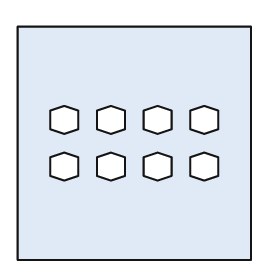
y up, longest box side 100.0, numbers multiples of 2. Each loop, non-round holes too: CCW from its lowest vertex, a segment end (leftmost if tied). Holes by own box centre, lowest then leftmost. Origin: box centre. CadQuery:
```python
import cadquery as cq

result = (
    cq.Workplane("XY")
    .moveTo(-50.0, -50.0)
    .lineTo(50.0, -50.0)
    .lineTo(50.0, 50.0)
    .lineTo(-50.0, 50.0)
    .close()
    .moveTo(-30.0, -16.0)
    .lineTo(-24.0, -14.0)
    .lineTo(-24.0, -6.0)
    .lineTo(-30.0, -4.0)
    .lineTo(-36.0, -6.0)
    .lineTo(-36.0, -14.0)
    .close()
    .moveTo(-10.0, -16.0)
    .lineTo(-4.0, -14.0)
    .lineTo(-4.0, -6.0)
    .lineTo(-10.0, -4.0)
    .lineTo(-16.0, -6.0)
    .lineTo(-16.0, -14.0)
    .close()
    .moveTo(10.0, -16.0)
    .lineTo(16.0, -14.0)
    .lineTo(16.0, -6.0)
    .lineTo(10.0, -4.0)
    .lineTo(4.0, -6.0)
    .lineTo(4.0, -14.0)
    .close()
    .moveTo(30.0, -16.0)
    .lineTo(36.0, -14.0)
    .lineTo(36.0, -6.0)
    .lineTo(30.0, -4.0)
    .lineTo(24.0, -6.0)
    .lineTo(24.0, -14.0)
    .close()
    .moveTo(-30.0, 4.0)
    .lineTo(-24.0, 6.0)
    .lineTo(-24.0, 14.0)
    .lineTo(-30.0, 16.0)
    .lineTo(-36.0, 14.0)
    .lineTo(-36.0, 6.0)
    .close()
    .moveTo(-10.0, 4.0)
    .lineTo(-4.0, 6.0)
    .lineTo(-4.0, 14.0)
    .lineTo(-10.0, 16.0)
    .lineTo(-16.0, 14.0)
    .lineTo(-16.0, 6.0)
    .close()
    .moveTo(10.0, 4.0)
    .lineTo(16.0, 6.0)
    .lineTo(16.0, 14.0)
    .lineTo(10.0, 16.0)
    .lineTo(4.0, 14.0)
    .lineTo(4.0, 6.0)
    .close()
    .moveTo(30.0, 4.0)
    .lineTo(36.0, 6.0)
    .lineTo(36.0, 14.0)
    .lineTo(30.0, 16.0)
    .lineTo(24.0, 14.0)
    .lineTo(24.0, 6.0)
    .close()
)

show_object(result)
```